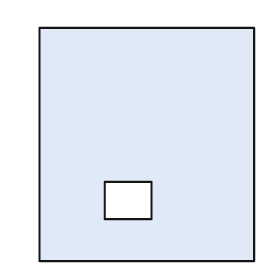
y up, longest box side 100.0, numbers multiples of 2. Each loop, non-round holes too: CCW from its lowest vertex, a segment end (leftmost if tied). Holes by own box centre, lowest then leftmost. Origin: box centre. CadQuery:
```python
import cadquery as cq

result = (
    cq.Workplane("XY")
    .moveTo(-46.0, -50.0)
    .lineTo(46.0, -50.0)
    .lineTo(46.0, 50.0)
    .lineTo(-46.0, 50.0)
    .close()
    .moveTo(-18.0, -32.0)
    .lineTo(2.0, -32.0)
    .lineTo(2.0, -16.0)
    .lineTo(-18.0, -16.0)
    .close()
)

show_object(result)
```